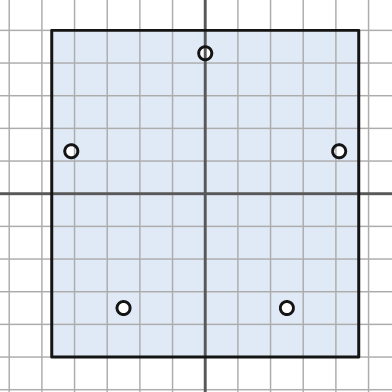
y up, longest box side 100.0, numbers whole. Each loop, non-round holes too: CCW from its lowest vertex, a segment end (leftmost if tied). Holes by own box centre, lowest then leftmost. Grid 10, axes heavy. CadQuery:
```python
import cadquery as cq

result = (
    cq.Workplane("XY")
    .moveTo(-47.0, -50.0)
    .lineTo(47.0, -50.0)
    .lineTo(47.0, 50.0)
    .lineTo(-47.0, 50.0)
    .close()
    .moveTo(-25.0, -35.0)
    .circle(2.0)
    .moveTo(25.0, -35.0)
    .circle(2.0)
    .moveTo(-41.0, 13.0)
    .circle(2.0)
    .moveTo(41.0, 13.0)
    .circle(2.0)
    .moveTo(0.0, 43.0)
    .circle(2.0)
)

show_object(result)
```